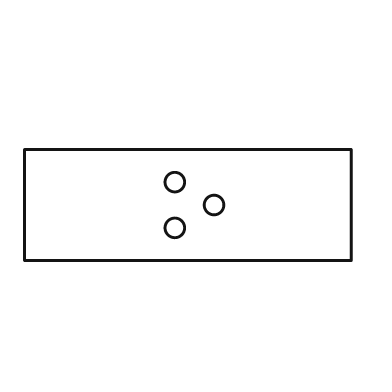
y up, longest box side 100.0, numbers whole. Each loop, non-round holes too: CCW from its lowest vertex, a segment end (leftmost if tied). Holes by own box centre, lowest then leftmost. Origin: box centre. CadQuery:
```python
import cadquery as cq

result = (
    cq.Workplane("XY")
    .moveTo(-50.0, -17.0)
    .lineTo(50.0, -17.0)
    .lineTo(50.0, 17.0)
    .lineTo(-50.0, 17.0)
    .close()
    .moveTo(-4.0, -7.0)
    .circle(3.0)
    .moveTo(8.0, 0.0)
    .circle(3.0)
    .moveTo(-4.0, 7.0)
    .circle(3.0)
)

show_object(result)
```